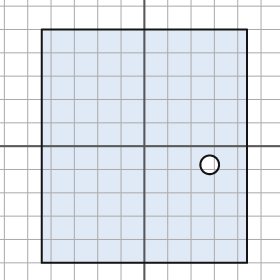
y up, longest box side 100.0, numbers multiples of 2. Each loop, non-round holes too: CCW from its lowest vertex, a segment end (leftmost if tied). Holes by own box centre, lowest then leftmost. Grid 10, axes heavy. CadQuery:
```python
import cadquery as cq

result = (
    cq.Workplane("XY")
    .moveTo(-44.0, -50.0)
    .lineTo(44.0, -50.0)
    .lineTo(44.0, 50.0)
    .lineTo(-44.0, 50.0)
    .close()
    .moveTo(28.0, -8.0)
    .circle(4.0)
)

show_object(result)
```